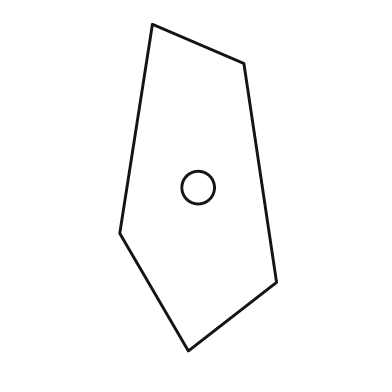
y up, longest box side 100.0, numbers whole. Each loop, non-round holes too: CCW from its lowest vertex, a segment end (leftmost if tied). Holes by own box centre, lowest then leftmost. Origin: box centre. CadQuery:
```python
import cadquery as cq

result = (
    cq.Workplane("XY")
    .moveTo(-3.0, -50.0)
    .lineTo(24.0, -29.0)
    .lineTo(14.0, 38.0)
    .lineTo(-14.0, 50.0)
    .lineTo(-24.0, -14.0)
    .close()
    .moveTo(0.0, 0.0)
    .circle(5.0)
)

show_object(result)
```